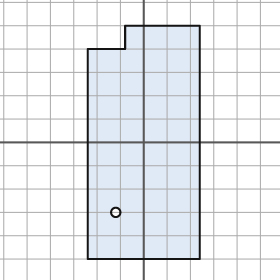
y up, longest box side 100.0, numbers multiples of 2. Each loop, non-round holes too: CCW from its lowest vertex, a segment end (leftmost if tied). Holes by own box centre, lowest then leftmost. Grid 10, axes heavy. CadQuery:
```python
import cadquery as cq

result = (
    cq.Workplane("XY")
    .moveTo(-24.0, -50.0)
    .lineTo(24.0, -50.0)
    .lineTo(24.0, 50.0)
    .lineTo(-8.0, 50.0)
    .lineTo(-8.0, 40.0)
    .lineTo(-24.0, 40.0)
    .close()
    .moveTo(-12.0, -30.0)
    .circle(2.0)
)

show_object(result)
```